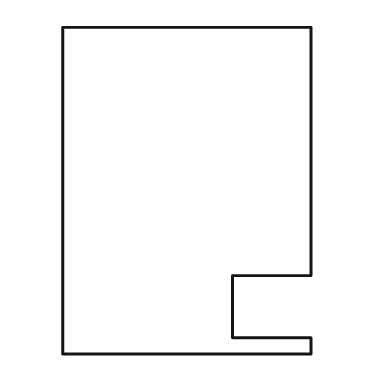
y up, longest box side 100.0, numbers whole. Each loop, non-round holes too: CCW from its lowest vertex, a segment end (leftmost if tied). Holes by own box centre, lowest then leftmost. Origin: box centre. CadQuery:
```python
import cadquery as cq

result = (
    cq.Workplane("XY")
    .moveTo(-38.0, -50.0)
    .lineTo(38.0, -50.0)
    .lineTo(38.0, -45.0)
    .lineTo(14.0, -45.0)
    .lineTo(14.0, -26.0)
    .lineTo(38.0, -26.0)
    .lineTo(38.0, 50.0)
    .lineTo(-38.0, 50.0)
    .close()
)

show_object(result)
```